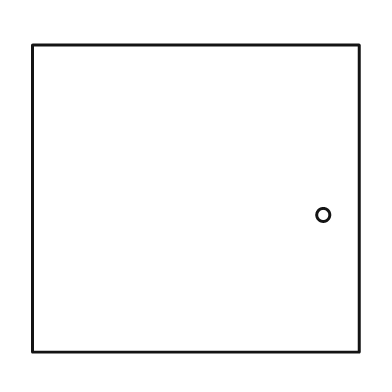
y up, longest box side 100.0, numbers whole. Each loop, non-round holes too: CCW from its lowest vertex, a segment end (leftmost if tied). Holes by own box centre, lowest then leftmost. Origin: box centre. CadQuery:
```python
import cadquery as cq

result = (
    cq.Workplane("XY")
    .moveTo(-50.0, -47.0)
    .lineTo(50.0, -47.0)
    .lineTo(50.0, 47.0)
    .lineTo(-50.0, 47.0)
    .close()
    .moveTo(39.0, -5.0)
    .circle(2.0)
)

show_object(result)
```